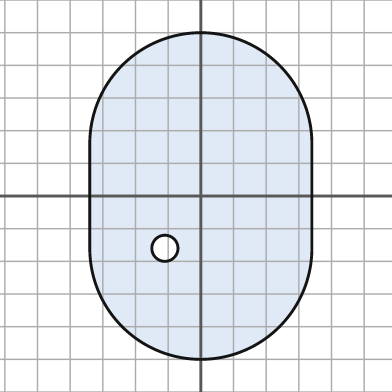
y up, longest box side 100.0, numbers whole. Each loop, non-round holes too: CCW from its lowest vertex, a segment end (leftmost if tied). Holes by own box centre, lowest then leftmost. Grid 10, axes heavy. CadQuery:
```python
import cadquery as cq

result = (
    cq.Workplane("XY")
    .moveTo(-34.0, -16.0)
    .threePointArc((0.0, -50.0), (34.0, -16.0))
    .lineTo(34.0, 16.0)
    .threePointArc((0.0, 50.0), (-34.0, 16.0))
    .close()
    .moveTo(-11.0, -16.0)
    .circle(4.0)
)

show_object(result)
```